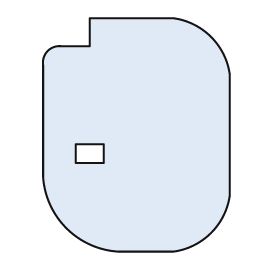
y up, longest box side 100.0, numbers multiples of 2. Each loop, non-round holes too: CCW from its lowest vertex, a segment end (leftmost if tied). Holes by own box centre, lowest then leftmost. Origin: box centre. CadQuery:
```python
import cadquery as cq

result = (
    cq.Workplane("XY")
    .moveTo(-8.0, -50.0)
    .lineTo(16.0, -50.0)
    .threePointArc((32.0, -42.0), (40.0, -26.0))
    .lineTo(40.0, 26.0)
    .threePointArc((32.0, 42.0), (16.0, 50.0))
    .lineTo(-20.0, 50.0)
    .lineTo(-20.0, 38.0)
    .lineTo(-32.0, 38.0)
    .threePointArc((-38.0, 36.0), (-40.0, 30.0))
    .lineTo(-40.0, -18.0)
    .threePointArc((-30.0, -40.0), (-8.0, -50.0))
    .close()
    .moveTo(-26.0, -12.0)
    .lineTo(-14.0, -12.0)
    .lineTo(-14.0, -4.0)
    .lineTo(-26.0, -4.0)
    .close()
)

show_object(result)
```